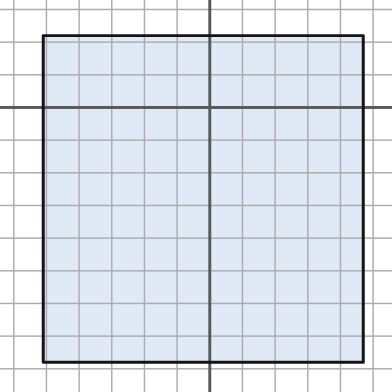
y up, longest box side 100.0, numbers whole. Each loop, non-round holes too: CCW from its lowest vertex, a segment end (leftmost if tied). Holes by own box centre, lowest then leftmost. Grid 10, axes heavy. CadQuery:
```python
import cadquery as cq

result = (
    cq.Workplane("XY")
    .moveTo(-51.0, -78.0)
    .lineTo(47.0, -78.0)
    .lineTo(47.0, 22.0)
    .lineTo(-51.0, 22.0)
    .close()
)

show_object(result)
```